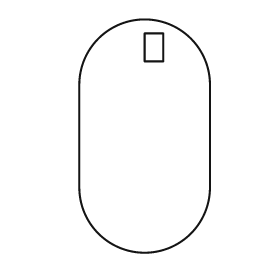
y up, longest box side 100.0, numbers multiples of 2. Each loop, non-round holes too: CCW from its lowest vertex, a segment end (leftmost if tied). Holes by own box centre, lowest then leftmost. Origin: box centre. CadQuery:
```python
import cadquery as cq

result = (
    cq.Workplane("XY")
    .moveTo(-28.0, -22.0)
    .threePointArc((0.0, -50.0), (28.0, -22.0))
    .lineTo(28.0, 22.0)
    .threePointArc((0.0, 50.0), (-28.0, 22.0))
    .close()
    .moveTo(0.0, 32.0)
    .lineTo(8.0, 32.0)
    .lineTo(8.0, 44.0)
    .lineTo(0.0, 44.0)
    .close()
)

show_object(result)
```